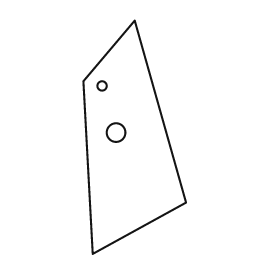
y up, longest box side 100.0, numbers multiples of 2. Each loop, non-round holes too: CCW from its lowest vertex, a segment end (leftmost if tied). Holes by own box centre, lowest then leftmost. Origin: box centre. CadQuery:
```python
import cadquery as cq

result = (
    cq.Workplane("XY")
    .moveTo(-18.0, -50.0)
    .lineTo(22.0, -28.0)
    .lineTo(0.0, 50.0)
    .lineTo(-22.0, 24.0)
    .close()
    .moveTo(-8.0, 2.0)
    .circle(4.0)
    .moveTo(-14.0, 22.0)
    .circle(2.0)
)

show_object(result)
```